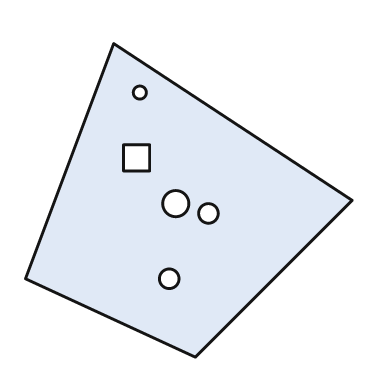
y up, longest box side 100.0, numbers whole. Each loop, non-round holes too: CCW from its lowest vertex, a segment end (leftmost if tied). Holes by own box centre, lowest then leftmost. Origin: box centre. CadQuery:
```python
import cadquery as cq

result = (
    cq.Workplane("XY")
    .moveTo(2.0, -48.0)
    .lineTo(50.0, 0.0)
    .lineTo(-23.0, 48.0)
    .lineTo(-50.0, -24.0)
    .close()
    .moveTo(-6.0, -24.0)
    .circle(3.0)
    .moveTo(6.0, -4.0)
    .circle(3.0)
    .moveTo(-4.0, -1.0)
    .circle(4.0)
    .moveTo(-20.0, 9.0)
    .lineTo(-12.0, 9.0)
    .lineTo(-12.0, 17.0)
    .lineTo(-20.0, 17.0)
    .close()
    .moveTo(-15.0, 33.0)
    .circle(2.0)
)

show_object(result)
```